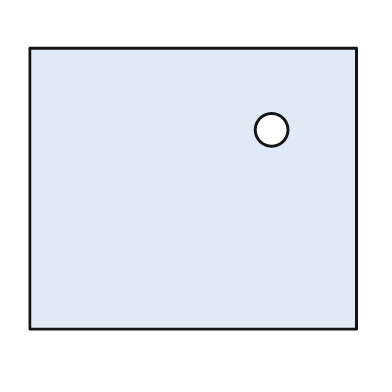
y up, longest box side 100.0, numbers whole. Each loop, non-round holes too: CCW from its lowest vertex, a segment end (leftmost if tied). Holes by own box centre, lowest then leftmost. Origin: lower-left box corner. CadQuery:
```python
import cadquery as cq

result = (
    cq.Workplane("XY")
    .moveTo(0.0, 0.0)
    .lineTo(100.0, 0.0)
    .lineTo(100.0, 86.0)
    .lineTo(0.0, 86.0)
    .close()
    .moveTo(74.0, 61.0)
    .circle(5.0)
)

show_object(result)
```